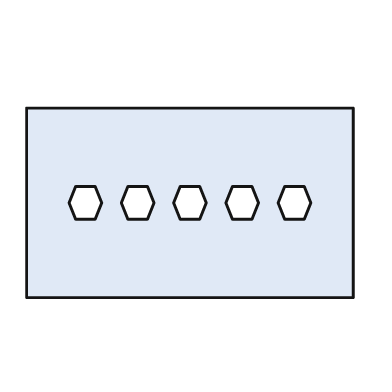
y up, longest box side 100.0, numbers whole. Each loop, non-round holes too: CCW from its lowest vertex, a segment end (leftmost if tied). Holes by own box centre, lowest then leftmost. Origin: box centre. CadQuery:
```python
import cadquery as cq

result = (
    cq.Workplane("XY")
    .moveTo(-50.0, -29.0)
    .lineTo(50.0, -29.0)
    .lineTo(50.0, 29.0)
    .lineTo(-50.0, 29.0)
    .close()
    .moveTo(-35.0, -5.0)
    .lineTo(-29.0, -5.0)
    .lineTo(-27.0, 0.0)
    .lineTo(-29.0, 5.0)
    .lineTo(-35.0, 5.0)
    .lineTo(-37.0, 0.0)
    .close()
    .moveTo(-19.0, -5.0)
    .lineTo(-13.0, -5.0)
    .lineTo(-11.0, 0.0)
    .lineTo(-13.0, 5.0)
    .lineTo(-19.0, 5.0)
    .lineTo(-21.0, 0.0)
    .close()
    .moveTo(-3.0, -5.0)
    .lineTo(3.0, -5.0)
    .lineTo(5.0, 0.0)
    .lineTo(3.0, 5.0)
    .lineTo(-3.0, 5.0)
    .lineTo(-5.0, 0.0)
    .close()
    .moveTo(13.0, -5.0)
    .lineTo(19.0, -5.0)
    .lineTo(21.0, 0.0)
    .lineTo(19.0, 5.0)
    .lineTo(13.0, 5.0)
    .lineTo(11.0, 0.0)
    .close()
    .moveTo(29.0, -5.0)
    .lineTo(35.0, -5.0)
    .lineTo(37.0, 0.0)
    .lineTo(35.0, 5.0)
    .lineTo(29.0, 5.0)
    .lineTo(27.0, 0.0)
    .close()
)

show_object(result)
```